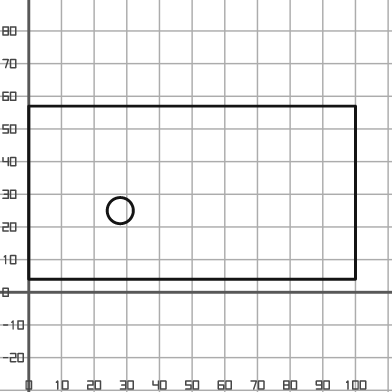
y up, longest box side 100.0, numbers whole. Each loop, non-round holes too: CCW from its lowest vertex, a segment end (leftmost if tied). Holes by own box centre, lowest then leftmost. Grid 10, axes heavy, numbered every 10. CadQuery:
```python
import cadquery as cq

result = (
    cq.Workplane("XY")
    .moveTo(0.0, 4.0)
    .lineTo(100.0, 4.0)
    .lineTo(100.0, 57.0)
    .lineTo(0.0, 57.0)
    .close()
    .moveTo(28.0, 25.0)
    .circle(4.0)
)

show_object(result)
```